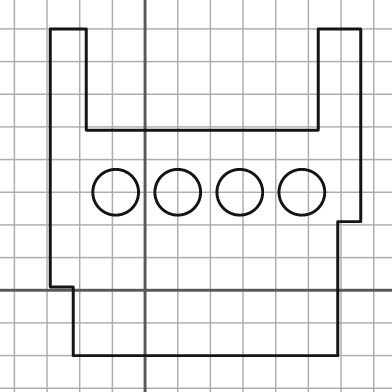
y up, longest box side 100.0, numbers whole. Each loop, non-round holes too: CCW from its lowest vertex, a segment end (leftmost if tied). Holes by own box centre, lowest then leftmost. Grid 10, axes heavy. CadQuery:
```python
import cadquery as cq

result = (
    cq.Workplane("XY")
    .moveTo(-22.0, -20.0)
    .lineTo(59.0, -20.0)
    .lineTo(59.0, 21.0)
    .lineTo(66.0, 21.0)
    .lineTo(66.0, 80.0)
    .lineTo(53.0, 80.0)
    .lineTo(53.0, 49.0)
    .lineTo(-18.0, 49.0)
    .lineTo(-18.0, 80.0)
    .lineTo(-29.0, 80.0)
    .lineTo(-29.0, 1.0)
    .lineTo(-22.0, 1.0)
    .close()
    .moveTo(-9.0, 30.0)
    .circle(7.0)
    .moveTo(10.0, 30.0)
    .circle(7.0)
    .moveTo(29.0, 30.0)
    .circle(7.0)
    .moveTo(48.0, 30.0)
    .circle(7.0)
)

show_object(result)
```